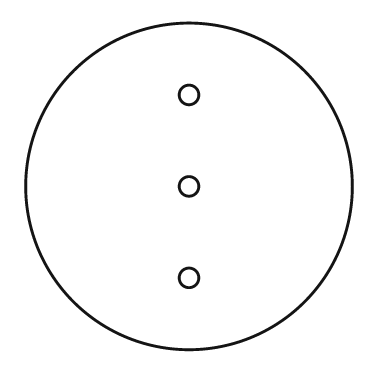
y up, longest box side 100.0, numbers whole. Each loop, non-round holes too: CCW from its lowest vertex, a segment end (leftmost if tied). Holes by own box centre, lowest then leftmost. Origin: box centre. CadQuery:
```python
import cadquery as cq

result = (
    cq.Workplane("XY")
    .moveTo(0.0, 0.0)
    .circle(50.0)
    .moveTo(0.0, -28.0)
    .circle(3.0)
    .moveTo(0.0, 0.0)
    .circle(3.0)
    .moveTo(0.0, 28.0)
    .circle(3.0)
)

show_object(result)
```